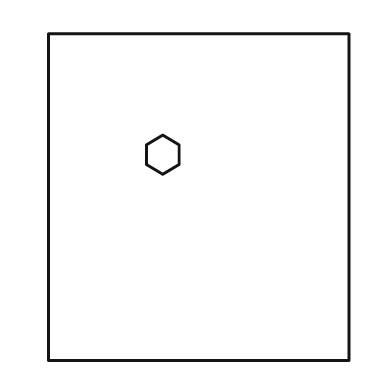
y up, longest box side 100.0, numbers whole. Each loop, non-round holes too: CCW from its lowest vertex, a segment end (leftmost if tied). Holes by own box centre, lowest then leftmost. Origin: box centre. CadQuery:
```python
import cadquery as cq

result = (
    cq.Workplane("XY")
    .moveTo(-46.0, -50.0)
    .lineTo(46.0, -50.0)
    .lineTo(46.0, 50.0)
    .lineTo(-46.0, 50.0)
    .close()
    .moveTo(-11.0, 7.0)
    .lineTo(-6.0, 10.0)
    .lineTo(-6.0, 16.0)
    .lineTo(-11.0, 19.0)
    .lineTo(-16.0, 16.0)
    .lineTo(-16.0, 10.0)
    .close()
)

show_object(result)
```